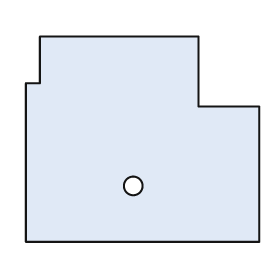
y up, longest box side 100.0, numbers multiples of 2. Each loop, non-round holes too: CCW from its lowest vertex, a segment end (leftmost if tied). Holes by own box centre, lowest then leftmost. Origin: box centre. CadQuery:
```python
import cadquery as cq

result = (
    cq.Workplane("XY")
    .moveTo(-50.0, -44.0)
    .lineTo(50.0, -44.0)
    .lineTo(50.0, 14.0)
    .lineTo(24.0, 14.0)
    .lineTo(24.0, 44.0)
    .lineTo(-44.0, 44.0)
    .lineTo(-44.0, 24.0)
    .lineTo(-50.0, 24.0)
    .close()
    .moveTo(-4.0, -20.0)
    .circle(4.0)
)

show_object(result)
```